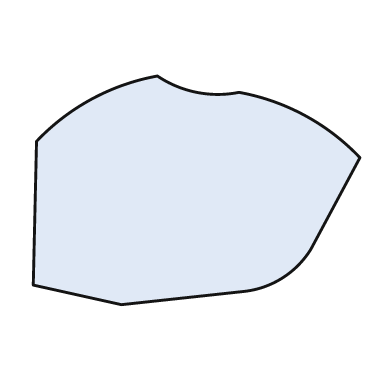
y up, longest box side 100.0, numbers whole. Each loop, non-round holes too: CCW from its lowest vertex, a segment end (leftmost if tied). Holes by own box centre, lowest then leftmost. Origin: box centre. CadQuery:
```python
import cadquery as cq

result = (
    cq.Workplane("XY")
    .moveTo(-23.0, -35.0)
    .lineTo(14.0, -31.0)
    .threePointArc((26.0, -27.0), (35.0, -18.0))
    .lineTo(50.0, 10.0)
    .threePointArc((33.0, 23.0), (13.0, 30.0))
    .threePointArc((0.0, 30.0), (-12.0, 35.0))
    .threePointArc((-32.0, 28.0), (-49.0, 15.0))
    .lineTo(-50.0, -29.0)
    .close()
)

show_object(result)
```